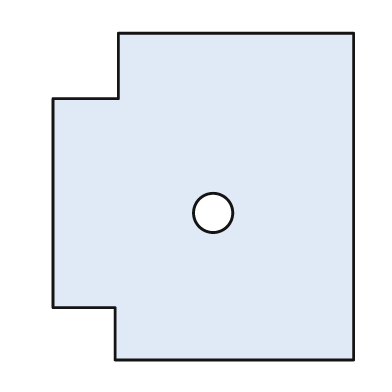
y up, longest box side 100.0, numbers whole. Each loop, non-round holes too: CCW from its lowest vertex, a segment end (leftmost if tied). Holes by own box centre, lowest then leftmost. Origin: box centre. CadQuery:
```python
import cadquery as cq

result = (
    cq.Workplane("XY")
    .moveTo(-27.0, -50.0)
    .lineTo(46.0, -50.0)
    .lineTo(46.0, 50.0)
    .lineTo(-26.0, 50.0)
    .lineTo(-26.0, 30.0)
    .lineTo(-46.0, 30.0)
    .lineTo(-46.0, -34.0)
    .lineTo(-27.0, -34.0)
    .close()
    .moveTo(3.0, -5.0)
    .circle(6.0)
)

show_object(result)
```